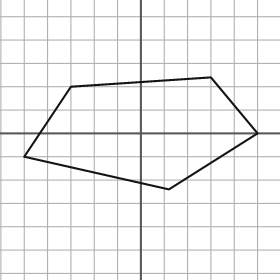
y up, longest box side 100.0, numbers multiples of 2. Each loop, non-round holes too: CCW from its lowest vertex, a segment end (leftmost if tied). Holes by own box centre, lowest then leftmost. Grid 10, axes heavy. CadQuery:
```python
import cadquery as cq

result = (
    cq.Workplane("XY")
    .moveTo(12.0, -24.0)
    .lineTo(50.0, 0.0)
    .lineTo(30.0, 24.0)
    .lineTo(-30.0, 20.0)
    .lineTo(-50.0, -10.0)
    .close()
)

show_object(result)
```